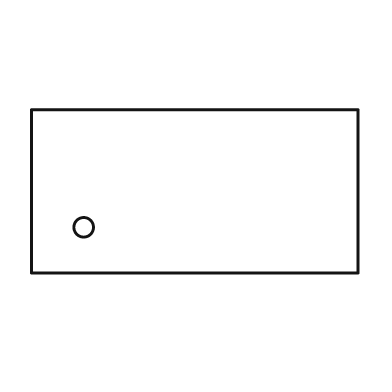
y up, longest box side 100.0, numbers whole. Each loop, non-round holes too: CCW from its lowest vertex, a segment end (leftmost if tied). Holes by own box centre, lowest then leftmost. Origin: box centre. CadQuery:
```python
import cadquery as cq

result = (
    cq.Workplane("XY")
    .moveTo(-50.0, -25.0)
    .lineTo(50.0, -25.0)
    .lineTo(50.0, 25.0)
    .lineTo(-50.0, 25.0)
    .close()
    .moveTo(-34.0, -11.0)
    .circle(3.0)
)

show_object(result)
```